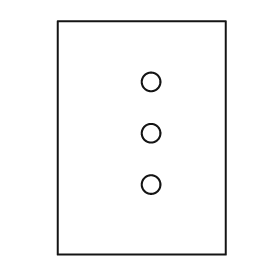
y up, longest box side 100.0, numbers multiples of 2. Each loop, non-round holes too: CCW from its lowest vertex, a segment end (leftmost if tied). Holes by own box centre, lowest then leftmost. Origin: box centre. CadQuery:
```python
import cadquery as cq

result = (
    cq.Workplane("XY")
    .moveTo(-36.0, -50.0)
    .lineTo(36.0, -50.0)
    .lineTo(36.0, 50.0)
    .lineTo(-36.0, 50.0)
    .close()
    .moveTo(4.0, -20.0)
    .circle(4.0)
    .moveTo(4.0, 2.0)
    .circle(4.0)
    .moveTo(4.0, 24.0)
    .circle(4.0)
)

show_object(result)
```